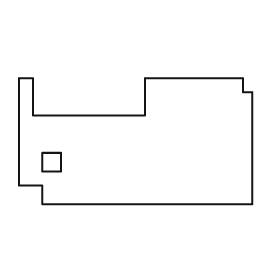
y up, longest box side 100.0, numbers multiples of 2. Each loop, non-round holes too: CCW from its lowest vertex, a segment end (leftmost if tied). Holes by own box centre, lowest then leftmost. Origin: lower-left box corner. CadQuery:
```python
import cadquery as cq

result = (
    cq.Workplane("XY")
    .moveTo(10.0, 0.0)
    .lineTo(100.0, 0.0)
    .lineTo(100.0, 48.0)
    .lineTo(96.0, 48.0)
    .lineTo(96.0, 54.0)
    .lineTo(54.0, 54.0)
    .lineTo(54.0, 38.0)
    .lineTo(6.0, 38.0)
    .lineTo(6.0, 54.0)
    .lineTo(0.0, 54.0)
    .lineTo(0.0, 8.0)
    .lineTo(10.0, 8.0)
    .close()
    .moveTo(10.0, 14.0)
    .lineTo(18.0, 14.0)
    .lineTo(18.0, 22.0)
    .lineTo(10.0, 22.0)
    .close()
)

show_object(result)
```